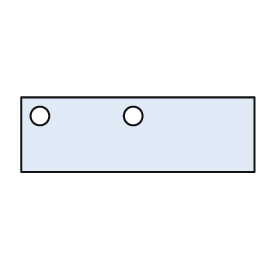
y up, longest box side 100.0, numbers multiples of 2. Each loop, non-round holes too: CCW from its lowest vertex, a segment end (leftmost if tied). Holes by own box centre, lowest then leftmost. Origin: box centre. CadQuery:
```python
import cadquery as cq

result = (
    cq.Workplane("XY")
    .moveTo(-50.0, -16.0)
    .lineTo(50.0, -16.0)
    .lineTo(50.0, 16.0)
    .lineTo(-50.0, 16.0)
    .close()
    .moveTo(-42.0, 8.0)
    .circle(4.0)
    .moveTo(-2.0, 8.0)
    .circle(4.0)
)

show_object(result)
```